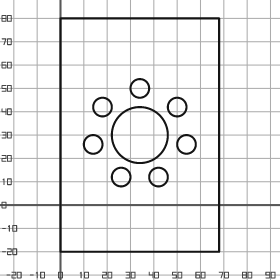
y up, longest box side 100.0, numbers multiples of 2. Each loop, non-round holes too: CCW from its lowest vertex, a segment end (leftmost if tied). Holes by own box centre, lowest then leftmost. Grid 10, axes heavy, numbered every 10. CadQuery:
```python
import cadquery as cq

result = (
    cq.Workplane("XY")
    .moveTo(0.0, -20.0)
    .lineTo(68.0, -20.0)
    .lineTo(68.0, 80.0)
    .lineTo(0.0, 80.0)
    .close()
    .moveTo(26.0, 12.0)
    .circle(4.0)
    .moveTo(42.0, 12.0)
    .circle(4.0)
    .moveTo(14.0, 26.0)
    .circle(4.0)
    .moveTo(54.0, 26.0)
    .circle(4.0)
    .moveTo(34.0, 30.0)
    .circle(12.0)
    .moveTo(18.0, 42.0)
    .circle(4.0)
    .moveTo(50.0, 42.0)
    .circle(4.0)
    .moveTo(34.0, 50.0)
    .circle(4.0)
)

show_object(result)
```